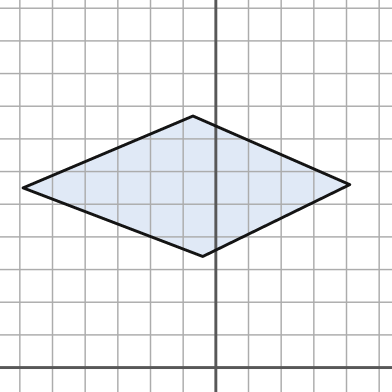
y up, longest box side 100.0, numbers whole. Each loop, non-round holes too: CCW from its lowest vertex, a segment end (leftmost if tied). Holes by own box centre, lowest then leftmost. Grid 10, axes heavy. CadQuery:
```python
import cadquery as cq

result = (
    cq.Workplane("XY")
    .moveTo(-4.0, 34.0)
    .lineTo(41.0, 56.0)
    .lineTo(-7.0, 77.0)
    .lineTo(-59.0, 55.0)
    .close()
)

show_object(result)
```